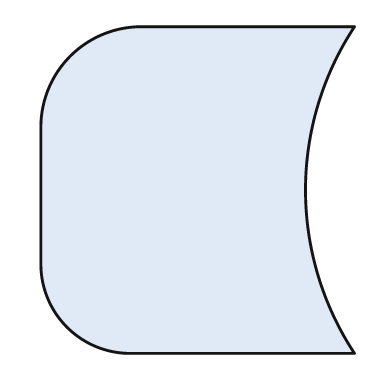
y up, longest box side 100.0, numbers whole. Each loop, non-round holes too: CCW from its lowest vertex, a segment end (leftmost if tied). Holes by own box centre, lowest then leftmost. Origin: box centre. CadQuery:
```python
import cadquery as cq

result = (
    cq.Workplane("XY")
    .moveTo(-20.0, -50.0)
    .lineTo(48.0, -50.0)
    .threePointArc((33.0, 0.0), (48.0, 50.0))
    .lineTo(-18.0, 50.0)
    .threePointArc((-39.0, 41.0), (-48.0, 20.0))
    .lineTo(-48.0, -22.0)
    .threePointArc((-40.0, -42.0), (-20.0, -50.0))
    .close()
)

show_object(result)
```